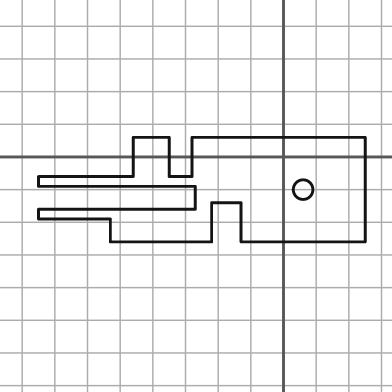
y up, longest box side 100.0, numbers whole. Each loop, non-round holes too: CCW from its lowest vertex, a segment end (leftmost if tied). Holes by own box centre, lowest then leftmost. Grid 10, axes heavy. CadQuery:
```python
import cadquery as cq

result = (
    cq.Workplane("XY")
    .moveTo(-53.0, -26.0)
    .lineTo(-22.0, -26.0)
    .lineTo(-22.0, -14.0)
    .lineTo(-13.0, -14.0)
    .lineTo(-13.0, -26.0)
    .lineTo(25.0, -26.0)
    .lineTo(25.0, 6.0)
    .lineTo(-28.0, 6.0)
    .lineTo(-28.0, -6.0)
    .lineTo(-35.0, -6.0)
    .lineTo(-35.0, 6.0)
    .lineTo(-46.0, 6.0)
    .lineTo(-46.0, -6.0)
    .lineTo(-75.0, -6.0)
    .lineTo(-75.0, -9.0)
    .lineTo(-27.0, -9.0)
    .lineTo(-27.0, -16.0)
    .lineTo(-75.0, -16.0)
    .lineTo(-75.0, -19.0)
    .lineTo(-53.0, -19.0)
    .close()
    .moveTo(6.0, -10.0)
    .circle(3.0)
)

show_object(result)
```